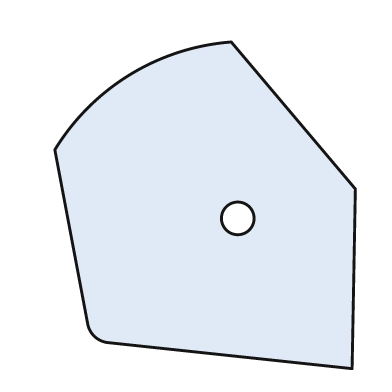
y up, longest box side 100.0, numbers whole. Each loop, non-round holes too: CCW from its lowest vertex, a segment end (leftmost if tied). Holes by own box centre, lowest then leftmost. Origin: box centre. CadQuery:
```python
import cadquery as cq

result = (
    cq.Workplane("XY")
    .moveTo(45.0, -50.0)
    .lineTo(46.0, 5.0)
    .lineTo(8.0, 50.0)
    .threePointArc((-23.0, 40.0), (-46.0, 17.0))
    .lineTo(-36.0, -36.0)
    .threePointArc((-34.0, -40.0), (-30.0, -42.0))
    .close()
    .moveTo(10.0, -4.0)
    .circle(5.0)
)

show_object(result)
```